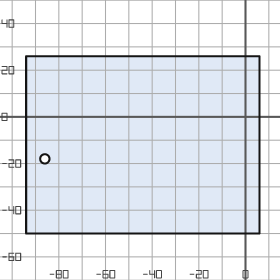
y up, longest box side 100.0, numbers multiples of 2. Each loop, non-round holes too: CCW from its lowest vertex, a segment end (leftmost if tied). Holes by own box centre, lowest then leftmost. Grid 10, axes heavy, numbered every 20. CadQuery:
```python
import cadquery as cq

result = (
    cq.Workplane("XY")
    .moveTo(-94.0, -50.0)
    .lineTo(6.0, -50.0)
    .lineTo(6.0, 26.0)
    .lineTo(-94.0, 26.0)
    .close()
    .moveTo(-86.0, -18.0)
    .circle(2.0)
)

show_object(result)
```